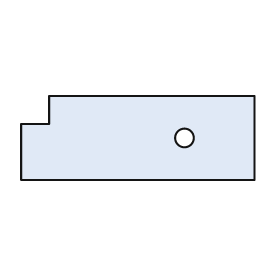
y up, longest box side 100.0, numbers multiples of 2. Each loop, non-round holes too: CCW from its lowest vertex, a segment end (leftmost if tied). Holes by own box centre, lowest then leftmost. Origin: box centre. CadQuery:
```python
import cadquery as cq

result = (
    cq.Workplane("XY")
    .moveTo(-50.0, -18.0)
    .lineTo(50.0, -18.0)
    .lineTo(50.0, 18.0)
    .lineTo(-38.0, 18.0)
    .lineTo(-38.0, 6.0)
    .lineTo(-50.0, 6.0)
    .close()
    .moveTo(20.0, 0.0)
    .circle(4.0)
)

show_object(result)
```